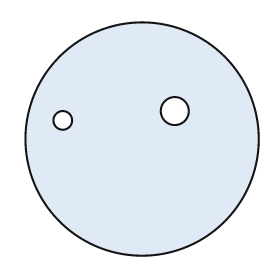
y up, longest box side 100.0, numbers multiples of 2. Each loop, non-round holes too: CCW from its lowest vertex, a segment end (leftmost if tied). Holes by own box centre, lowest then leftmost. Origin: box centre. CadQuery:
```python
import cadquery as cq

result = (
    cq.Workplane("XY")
    .moveTo(0.0, 0.0)
    .circle(50.0)
    .moveTo(-34.0, 8.0)
    .circle(4.0)
    .moveTo(14.0, 12.0)
    .circle(6.0)
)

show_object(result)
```